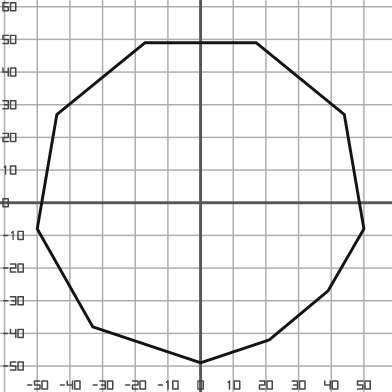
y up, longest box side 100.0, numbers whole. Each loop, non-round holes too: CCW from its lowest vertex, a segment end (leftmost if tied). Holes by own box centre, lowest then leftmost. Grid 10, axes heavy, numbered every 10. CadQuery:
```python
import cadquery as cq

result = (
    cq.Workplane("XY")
    .moveTo(0.0, -49.0)
    .lineTo(21.0, -42.0)
    .lineTo(39.0, -27.0)
    .lineTo(50.0, -8.0)
    .lineTo(44.0, 27.0)
    .lineTo(17.0, 49.0)
    .lineTo(-17.0, 49.0)
    .lineTo(-44.0, 27.0)
    .lineTo(-50.0, -8.0)
    .lineTo(-33.0, -38.0)
    .close()
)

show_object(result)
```